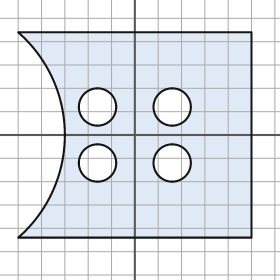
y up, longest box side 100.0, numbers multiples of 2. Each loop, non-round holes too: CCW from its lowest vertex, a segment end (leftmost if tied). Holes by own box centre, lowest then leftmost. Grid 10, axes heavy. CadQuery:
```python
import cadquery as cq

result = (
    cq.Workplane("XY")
    .moveTo(-50.0, -44.0)
    .lineTo(50.0, -44.0)
    .lineTo(50.0, 44.0)
    .lineTo(-50.0, 44.0)
    .threePointArc((-30.0, 0.0), (-50.0, -44.0))
    .close()
    .moveTo(-16.0, -12.0)
    .circle(8.0)
    .moveTo(16.0, -12.0)
    .circle(8.0)
    .moveTo(-16.0, 12.0)
    .circle(8.0)
    .moveTo(16.0, 12.0)
    .circle(8.0)
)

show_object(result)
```